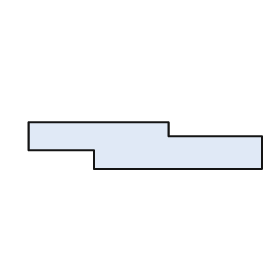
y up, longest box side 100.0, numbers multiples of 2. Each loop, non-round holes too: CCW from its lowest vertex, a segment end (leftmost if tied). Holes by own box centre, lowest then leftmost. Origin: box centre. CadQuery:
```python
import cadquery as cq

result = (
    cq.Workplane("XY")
    .moveTo(-22.0, -10.0)
    .lineTo(50.0, -10.0)
    .lineTo(50.0, 4.0)
    .lineTo(10.0, 4.0)
    .lineTo(10.0, 10.0)
    .lineTo(-50.0, 10.0)
    .lineTo(-50.0, -2.0)
    .lineTo(-22.0, -2.0)
    .close()
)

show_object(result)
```